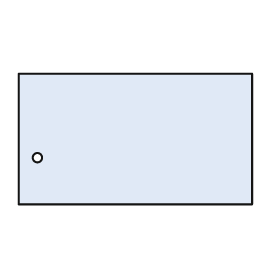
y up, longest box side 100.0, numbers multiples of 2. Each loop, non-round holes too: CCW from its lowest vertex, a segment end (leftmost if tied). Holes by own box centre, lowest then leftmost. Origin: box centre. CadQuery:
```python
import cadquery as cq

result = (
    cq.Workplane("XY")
    .moveTo(-50.0, -28.0)
    .lineTo(50.0, -28.0)
    .lineTo(50.0, 28.0)
    .lineTo(-50.0, 28.0)
    .close()
    .moveTo(-42.0, -8.0)
    .circle(2.0)
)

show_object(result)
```